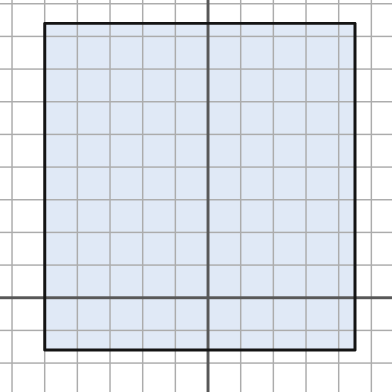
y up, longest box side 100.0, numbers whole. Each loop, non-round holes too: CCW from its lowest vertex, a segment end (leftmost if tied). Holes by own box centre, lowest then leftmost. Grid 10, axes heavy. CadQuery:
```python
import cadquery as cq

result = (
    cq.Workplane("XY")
    .moveTo(-50.0, -16.0)
    .lineTo(45.0, -16.0)
    .lineTo(45.0, 84.0)
    .lineTo(-50.0, 84.0)
    .close()
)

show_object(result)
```